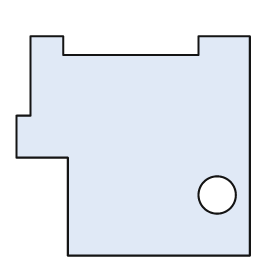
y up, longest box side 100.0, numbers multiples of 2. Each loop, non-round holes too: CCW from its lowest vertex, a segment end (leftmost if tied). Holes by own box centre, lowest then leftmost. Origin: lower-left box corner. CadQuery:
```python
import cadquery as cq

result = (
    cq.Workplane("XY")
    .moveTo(22.0, 0.0)
    .lineTo(100.0, 0.0)
    .lineTo(100.0, 94.0)
    .lineTo(78.0, 94.0)
    .lineTo(78.0, 86.0)
    .lineTo(20.0, 86.0)
    .lineTo(20.0, 94.0)
    .lineTo(6.0, 94.0)
    .lineTo(6.0, 60.0)
    .lineTo(0.0, 60.0)
    .lineTo(0.0, 42.0)
    .lineTo(22.0, 42.0)
    .close()
    .moveTo(86.0, 26.0)
    .circle(8.0)
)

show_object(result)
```